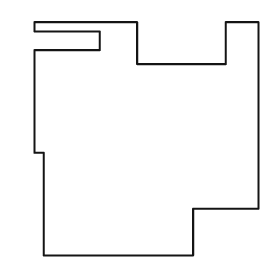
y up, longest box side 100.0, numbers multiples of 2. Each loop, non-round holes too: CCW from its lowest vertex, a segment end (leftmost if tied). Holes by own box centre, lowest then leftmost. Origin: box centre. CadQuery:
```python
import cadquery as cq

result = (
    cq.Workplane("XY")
    .moveTo(-44.0, -50.0)
    .lineTo(20.0, -50.0)
    .lineTo(20.0, -30.0)
    .lineTo(48.0, -30.0)
    .lineTo(48.0, 50.0)
    .lineTo(34.0, 50.0)
    .lineTo(34.0, 32.0)
    .lineTo(-4.0, 32.0)
    .lineTo(-4.0, 50.0)
    .lineTo(-48.0, 50.0)
    .lineTo(-48.0, 46.0)
    .lineTo(-20.0, 46.0)
    .lineTo(-20.0, 38.0)
    .lineTo(-48.0, 38.0)
    .lineTo(-48.0, -6.0)
    .lineTo(-44.0, -6.0)
    .close()
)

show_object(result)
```